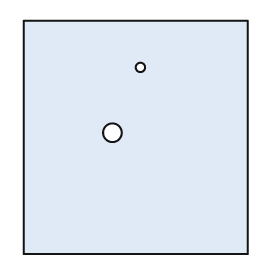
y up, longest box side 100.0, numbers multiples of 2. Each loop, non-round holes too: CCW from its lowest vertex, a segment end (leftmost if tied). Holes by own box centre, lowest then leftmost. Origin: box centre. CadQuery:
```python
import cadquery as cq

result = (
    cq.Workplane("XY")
    .moveTo(-48.0, -50.0)
    .lineTo(48.0, -50.0)
    .lineTo(48.0, 50.0)
    .lineTo(-48.0, 50.0)
    .close()
    .moveTo(-10.0, 2.0)
    .circle(4.0)
    .moveTo(2.0, 30.0)
    .circle(2.0)
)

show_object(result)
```